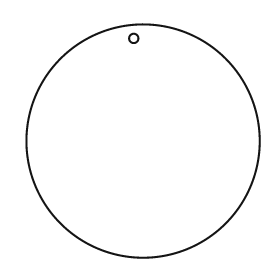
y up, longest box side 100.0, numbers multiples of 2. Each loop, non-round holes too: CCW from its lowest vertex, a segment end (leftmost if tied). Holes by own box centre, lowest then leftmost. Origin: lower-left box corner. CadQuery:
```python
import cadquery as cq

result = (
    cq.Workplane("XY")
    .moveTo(50.0, 50.0)
    .circle(50.0)
    .moveTo(46.0, 94.0)
    .circle(2.0)
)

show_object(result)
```